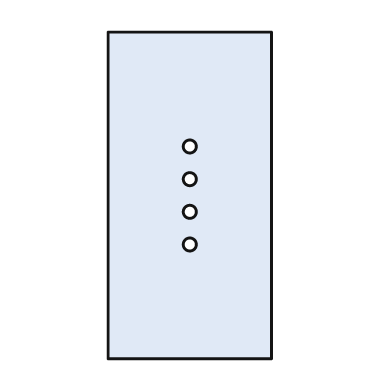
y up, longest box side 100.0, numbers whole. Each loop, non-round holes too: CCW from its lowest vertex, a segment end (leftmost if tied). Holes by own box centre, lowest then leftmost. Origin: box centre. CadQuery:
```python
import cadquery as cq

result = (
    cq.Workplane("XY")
    .moveTo(-25.0, -50.0)
    .lineTo(25.0, -50.0)
    .lineTo(25.0, 50.0)
    .lineTo(-25.0, 50.0)
    .close()
    .moveTo(0.0, -15.0)
    .circle(2.0)
    .moveTo(0.0, -5.0)
    .circle(2.0)
    .moveTo(0.0, 5.0)
    .circle(2.0)
    .moveTo(0.0, 15.0)
    .circle(2.0)
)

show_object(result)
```